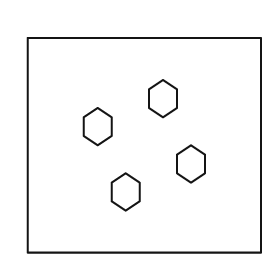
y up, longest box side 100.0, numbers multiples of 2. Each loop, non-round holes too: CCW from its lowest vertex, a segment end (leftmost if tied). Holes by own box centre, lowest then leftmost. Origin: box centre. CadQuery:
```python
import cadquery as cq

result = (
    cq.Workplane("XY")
    .moveTo(-50.0, -46.0)
    .lineTo(50.0, -46.0)
    .lineTo(50.0, 46.0)
    .lineTo(-50.0, 46.0)
    .close()
    .moveTo(-8.0, -28.0)
    .lineTo(-2.0, -24.0)
    .lineTo(-2.0, -16.0)
    .lineTo(-8.0, -12.0)
    .lineTo(-14.0, -16.0)
    .lineTo(-14.0, -24.0)
    .close()
    .moveTo(20.0, -16.0)
    .lineTo(26.0, -12.0)
    .lineTo(26.0, -4.0)
    .lineTo(20.0, 0.0)
    .lineTo(14.0, -4.0)
    .lineTo(14.0, -12.0)
    .close()
    .moveTo(-20.0, 0.0)
    .lineTo(-14.0, 4.0)
    .lineTo(-14.0, 12.0)
    .lineTo(-20.0, 16.0)
    .lineTo(-26.0, 12.0)
    .lineTo(-26.0, 4.0)
    .close()
    .moveTo(8.0, 12.0)
    .lineTo(14.0, 16.0)
    .lineTo(14.0, 24.0)
    .lineTo(8.0, 28.0)
    .lineTo(2.0, 24.0)
    .lineTo(2.0, 16.0)
    .close()
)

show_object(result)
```